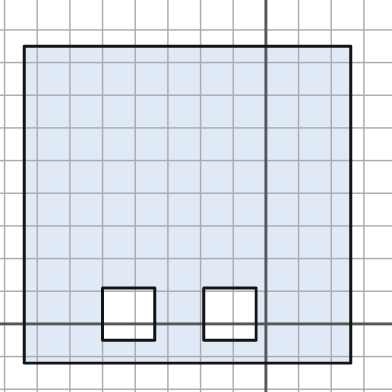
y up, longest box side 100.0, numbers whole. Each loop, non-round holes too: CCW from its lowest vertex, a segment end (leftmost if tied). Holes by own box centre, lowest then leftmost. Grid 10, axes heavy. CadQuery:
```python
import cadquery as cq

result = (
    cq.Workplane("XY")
    .moveTo(-74.0, -12.0)
    .lineTo(26.0, -12.0)
    .lineTo(26.0, 85.0)
    .lineTo(-74.0, 85.0)
    .close()
    .moveTo(-50.0, -5.0)
    .lineTo(-34.0, -5.0)
    .lineTo(-34.0, 11.0)
    .lineTo(-50.0, 11.0)
    .close()
    .moveTo(-19.0, -5.0)
    .lineTo(-3.0, -5.0)
    .lineTo(-3.0, 11.0)
    .lineTo(-19.0, 11.0)
    .close()
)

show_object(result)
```